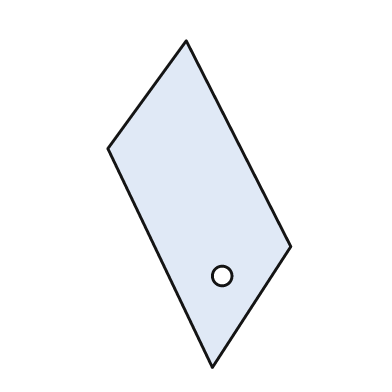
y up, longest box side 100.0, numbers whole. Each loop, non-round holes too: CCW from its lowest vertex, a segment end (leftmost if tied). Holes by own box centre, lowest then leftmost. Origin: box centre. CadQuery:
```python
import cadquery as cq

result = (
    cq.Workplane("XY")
    .moveTo(4.0, -50.0)
    .lineTo(28.0, -13.0)
    .lineTo(-4.0, 50.0)
    .lineTo(-28.0, 17.0)
    .close()
    .moveTo(7.0, -22.0)
    .circle(3.0)
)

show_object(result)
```